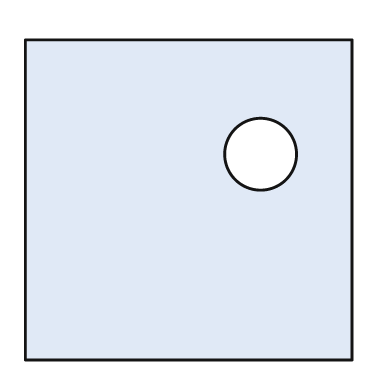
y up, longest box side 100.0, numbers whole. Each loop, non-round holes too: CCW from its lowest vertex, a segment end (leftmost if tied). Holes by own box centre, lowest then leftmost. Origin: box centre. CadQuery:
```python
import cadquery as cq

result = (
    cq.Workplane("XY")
    .moveTo(-50.0, -49.0)
    .lineTo(50.0, -49.0)
    .lineTo(50.0, 49.0)
    .lineTo(-50.0, 49.0)
    .close()
    .moveTo(22.0, 14.0)
    .circle(11.0)
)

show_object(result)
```